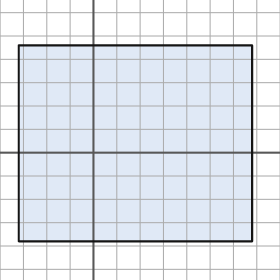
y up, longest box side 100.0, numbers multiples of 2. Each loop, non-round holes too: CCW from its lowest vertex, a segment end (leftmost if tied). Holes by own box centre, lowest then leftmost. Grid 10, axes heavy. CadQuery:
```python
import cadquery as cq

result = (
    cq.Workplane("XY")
    .moveTo(-32.0, -38.0)
    .lineTo(68.0, -38.0)
    .lineTo(68.0, 46.0)
    .lineTo(-32.0, 46.0)
    .close()
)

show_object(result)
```